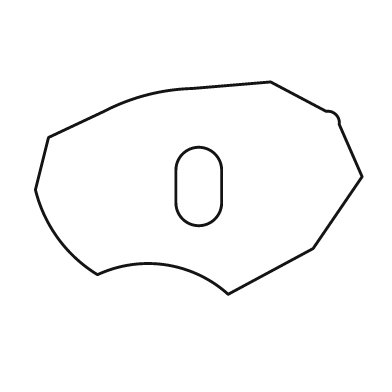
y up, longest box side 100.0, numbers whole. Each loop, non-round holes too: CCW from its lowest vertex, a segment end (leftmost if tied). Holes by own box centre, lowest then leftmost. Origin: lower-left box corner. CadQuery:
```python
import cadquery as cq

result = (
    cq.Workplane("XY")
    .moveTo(59.0, 0.0)
    .lineTo(85.0, 14.0)
    .lineTo(100.0, 36.0)
    .lineTo(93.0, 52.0)
    .threePointArc((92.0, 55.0), (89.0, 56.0))
    .lineTo(72.0, 65.0)
    .lineTo(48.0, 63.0)
    .threePointArc((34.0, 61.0), (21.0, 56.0))
    .lineTo(4.0, 48.0)
    .lineTo(0.0, 32.0)
    .threePointArc((7.0, 17.0), (19.0, 6.0))
    .threePointArc((40.0, 9.0), (59.0, 0.0))
    .close()
    .moveTo(43.0, 28.0)
    .threePointArc((50.0, 21.0), (57.0, 28.0))
    .lineTo(57.0, 38.0)
    .threePointArc((50.0, 45.0), (43.0, 38.0))
    .close()
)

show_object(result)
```